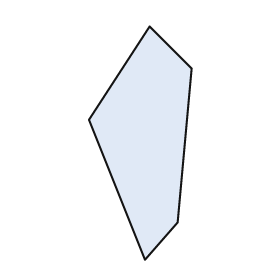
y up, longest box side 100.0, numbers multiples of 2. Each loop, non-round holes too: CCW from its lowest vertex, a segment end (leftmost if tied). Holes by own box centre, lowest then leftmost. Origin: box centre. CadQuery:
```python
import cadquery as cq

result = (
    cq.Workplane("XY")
    .moveTo(2.0, -50.0)
    .lineTo(16.0, -34.0)
    .lineTo(22.0, 32.0)
    .lineTo(4.0, 50.0)
    .lineTo(-22.0, 10.0)
    .close()
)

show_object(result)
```